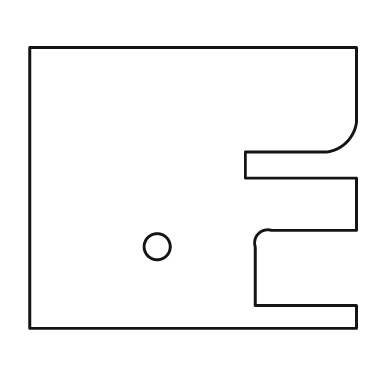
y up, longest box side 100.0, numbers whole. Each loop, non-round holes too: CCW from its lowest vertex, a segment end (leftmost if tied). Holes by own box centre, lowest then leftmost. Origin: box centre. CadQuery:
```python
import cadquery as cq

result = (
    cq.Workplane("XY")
    .moveTo(-50.0, -43.0)
    .lineTo(50.0, -43.0)
    .lineTo(50.0, -36.0)
    .lineTo(19.0, -36.0)
    .lineTo(19.0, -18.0)
    .threePointArc((20.0, -14.0), (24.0, -13.0))
    .lineTo(50.0, -13.0)
    .lineTo(50.0, 3.0)
    .lineTo(16.0, 3.0)
    .lineTo(16.0, 11.0)
    .lineTo(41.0, 11.0)
    .threePointArc((47.0, 14.0), (50.0, 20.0))
    .lineTo(50.0, 43.0)
    .lineTo(-50.0, 43.0)
    .close()
    .moveTo(-11.0, -18.0)
    .circle(4.0)
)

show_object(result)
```